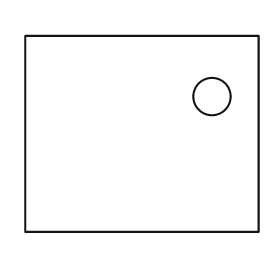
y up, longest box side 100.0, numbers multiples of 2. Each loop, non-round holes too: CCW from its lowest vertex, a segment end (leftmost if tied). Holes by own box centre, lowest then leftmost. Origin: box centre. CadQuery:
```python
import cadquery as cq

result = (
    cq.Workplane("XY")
    .moveTo(-50.0, -42.0)
    .lineTo(50.0, -42.0)
    .lineTo(50.0, 42.0)
    .lineTo(-50.0, 42.0)
    .close()
    .moveTo(30.0, 16.0)
    .circle(8.0)
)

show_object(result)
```